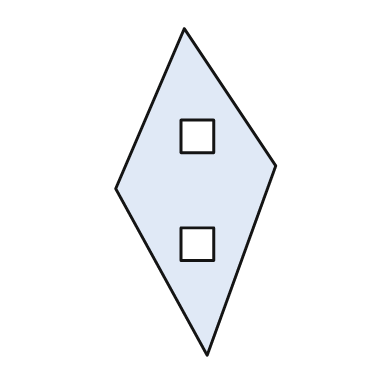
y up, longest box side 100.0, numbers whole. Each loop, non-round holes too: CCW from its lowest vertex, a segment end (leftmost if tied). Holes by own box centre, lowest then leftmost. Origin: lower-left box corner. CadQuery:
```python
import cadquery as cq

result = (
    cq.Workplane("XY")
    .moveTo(28.0, 0.0)
    .lineTo(49.0, 58.0)
    .lineTo(21.0, 100.0)
    .lineTo(0.0, 51.0)
    .close()
    .moveTo(20.0, 29.0)
    .lineTo(30.0, 29.0)
    .lineTo(30.0, 39.0)
    .lineTo(20.0, 39.0)
    .close()
    .moveTo(20.0, 62.0)
    .lineTo(30.0, 62.0)
    .lineTo(30.0, 72.0)
    .lineTo(20.0, 72.0)
    .close()
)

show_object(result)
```